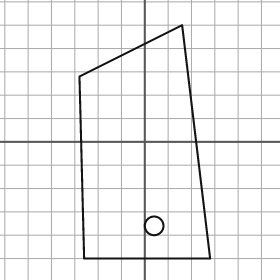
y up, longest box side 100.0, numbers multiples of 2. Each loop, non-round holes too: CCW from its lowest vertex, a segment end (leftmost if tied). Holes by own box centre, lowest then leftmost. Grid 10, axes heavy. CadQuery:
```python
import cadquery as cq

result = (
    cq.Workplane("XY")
    .moveTo(-26.0, -50.0)
    .lineTo(28.0, -50.0)
    .lineTo(16.0, 50.0)
    .lineTo(-28.0, 28.0)
    .close()
    .moveTo(4.0, -36.0)
    .circle(4.0)
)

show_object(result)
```